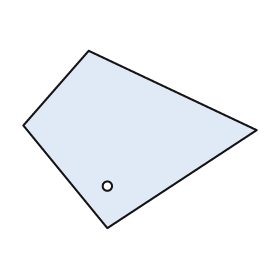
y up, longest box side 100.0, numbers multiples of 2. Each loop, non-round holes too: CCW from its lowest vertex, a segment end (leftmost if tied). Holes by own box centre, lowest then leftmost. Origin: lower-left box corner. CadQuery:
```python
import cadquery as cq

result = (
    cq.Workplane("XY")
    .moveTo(36.0, 0.0)
    .lineTo(100.0, 42.0)
    .lineTo(28.0, 76.0)
    .lineTo(0.0, 44.0)
    .close()
    .moveTo(36.0, 18.0)
    .circle(2.0)
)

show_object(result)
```